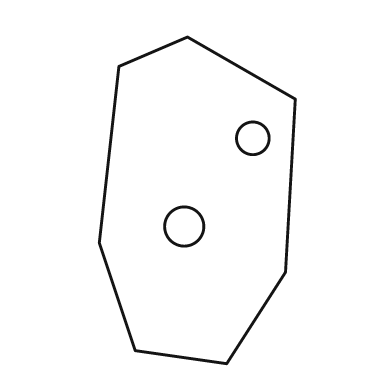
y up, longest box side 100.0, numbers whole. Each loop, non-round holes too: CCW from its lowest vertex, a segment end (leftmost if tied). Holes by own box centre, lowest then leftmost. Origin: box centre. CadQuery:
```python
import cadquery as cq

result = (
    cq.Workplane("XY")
    .moveTo(9.0, -50.0)
    .lineTo(27.0, -22.0)
    .lineTo(30.0, 31.0)
    .lineTo(-3.0, 50.0)
    .lineTo(-24.0, 41.0)
    .lineTo(-30.0, -13.0)
    .lineTo(-19.0, -46.0)
    .close()
    .moveTo(-4.0, -8.0)
    .circle(6.0)
    .moveTo(17.0, 19.0)
    .circle(5.0)
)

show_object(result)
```